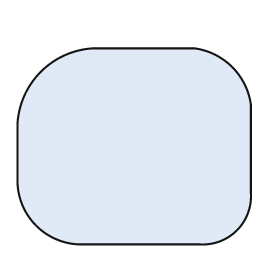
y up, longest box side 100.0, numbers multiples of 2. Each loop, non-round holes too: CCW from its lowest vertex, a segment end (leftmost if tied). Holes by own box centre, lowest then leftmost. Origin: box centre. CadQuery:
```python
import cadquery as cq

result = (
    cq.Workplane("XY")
    .moveTo(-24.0, -42.0)
    .lineTo(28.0, -42.0)
    .threePointArc((44.0, -36.0), (50.0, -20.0))
    .lineTo(50.0, 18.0)
    .threePointArc((42.0, 34.0), (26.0, 42.0))
    .lineTo(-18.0, 42.0)
    .threePointArc((-40.0, 32.0), (-50.0, 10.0))
    .lineTo(-50.0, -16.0)
    .threePointArc((-42.0, -34.0), (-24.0, -42.0))
    .close()
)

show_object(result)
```